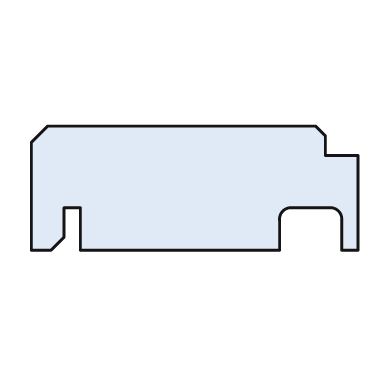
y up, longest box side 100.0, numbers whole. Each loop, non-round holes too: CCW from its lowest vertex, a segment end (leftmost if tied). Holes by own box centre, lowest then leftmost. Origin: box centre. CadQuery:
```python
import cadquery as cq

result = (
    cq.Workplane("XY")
    .moveTo(-50.0, -19.0)
    .lineTo(-44.0, -19.0)
    .lineTo(-40.0, -15.0)
    .lineTo(-40.0, -6.0)
    .lineTo(-35.0, -6.0)
    .lineTo(-35.0, -19.0)
    .lineTo(26.0, -19.0)
    .lineTo(26.0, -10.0)
    .threePointArc((27.0, -7.0), (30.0, -6.0))
    .lineTo(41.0, -6.0)
    .threePointArc((44.0, -7.0), (45.0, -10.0))
    .lineTo(45.0, -19.0)
    .lineTo(50.0, -19.0)
    .lineTo(50.0, 10.0)
    .lineTo(40.0, 10.0)
    .lineTo(40.0, 16.0)
    .lineTo(37.0, 19.0)
    .lineTo(-45.0, 19.0)
    .lineTo(-50.0, 14.0)
    .close()
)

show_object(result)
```